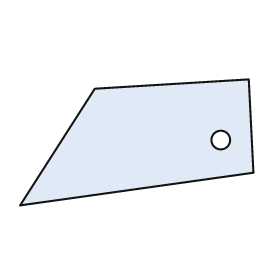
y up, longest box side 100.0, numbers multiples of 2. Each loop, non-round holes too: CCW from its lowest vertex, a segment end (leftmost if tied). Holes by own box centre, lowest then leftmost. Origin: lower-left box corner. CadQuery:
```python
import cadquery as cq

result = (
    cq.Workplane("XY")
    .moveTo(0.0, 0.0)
    .lineTo(100.0, 14.0)
    .lineTo(98.0, 54.0)
    .lineTo(32.0, 50.0)
    .close()
    .moveTo(86.0, 28.0)
    .circle(4.0)
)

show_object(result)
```